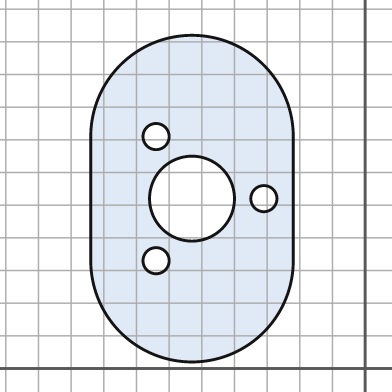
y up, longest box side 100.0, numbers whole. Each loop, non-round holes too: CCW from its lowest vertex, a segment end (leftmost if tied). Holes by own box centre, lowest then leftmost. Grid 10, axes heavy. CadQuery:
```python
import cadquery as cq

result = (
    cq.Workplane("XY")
    .moveTo(-84.0, 33.0)
    .threePointArc((-53.0, 2.0), (-22.0, 33.0))
    .lineTo(-22.0, 71.0)
    .threePointArc((-53.0, 102.0), (-84.0, 71.0))
    .close()
    .moveTo(-64.0, 33.0)
    .circle(4.0)
    .moveTo(-53.0, 52.0)
    .circle(13.0)
    .moveTo(-31.0, 52.0)
    .circle(4.0)
    .moveTo(-64.0, 71.0)
    .circle(4.0)
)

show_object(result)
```